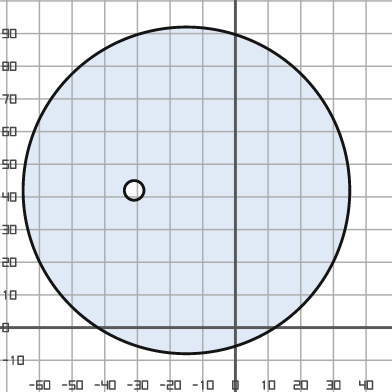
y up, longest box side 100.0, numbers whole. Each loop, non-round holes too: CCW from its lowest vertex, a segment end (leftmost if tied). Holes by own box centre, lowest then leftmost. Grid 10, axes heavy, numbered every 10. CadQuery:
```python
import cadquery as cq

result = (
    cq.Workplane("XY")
    .moveTo(-15.0, 42.0)
    .circle(50.0)
    .moveTo(-31.0, 42.0)
    .circle(3.0)
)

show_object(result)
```